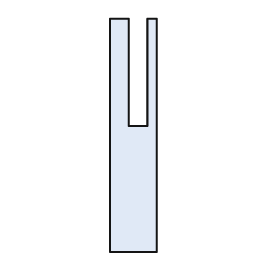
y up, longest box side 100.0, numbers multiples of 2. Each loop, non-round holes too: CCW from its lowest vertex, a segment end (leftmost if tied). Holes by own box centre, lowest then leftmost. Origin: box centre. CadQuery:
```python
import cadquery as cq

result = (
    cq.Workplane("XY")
    .moveTo(-10.0, -50.0)
    .lineTo(10.0, -50.0)
    .lineTo(10.0, 50.0)
    .lineTo(6.0, 50.0)
    .lineTo(6.0, 4.0)
    .lineTo(-2.0, 4.0)
    .lineTo(-2.0, 50.0)
    .lineTo(-10.0, 50.0)
    .close()
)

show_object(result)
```